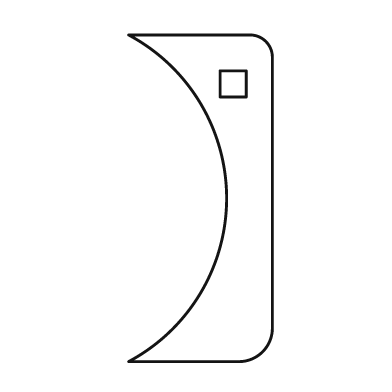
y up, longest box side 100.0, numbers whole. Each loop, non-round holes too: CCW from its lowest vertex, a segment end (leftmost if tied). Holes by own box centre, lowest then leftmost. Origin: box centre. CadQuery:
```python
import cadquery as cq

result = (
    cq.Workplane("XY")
    .moveTo(-22.0, -50.0)
    .lineTo(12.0, -50.0)
    .threePointArc((19.0, -47.0), (22.0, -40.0))
    .lineTo(22.0, 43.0)
    .threePointArc((20.0, 48.0), (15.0, 50.0))
    .lineTo(-22.0, 50.0)
    .threePointArc((8.0, 0.0), (-22.0, -50.0))
    .close()
    .moveTo(6.0, 31.0)
    .lineTo(14.0, 31.0)
    .lineTo(14.0, 39.0)
    .lineTo(6.0, 39.0)
    .close()
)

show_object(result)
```